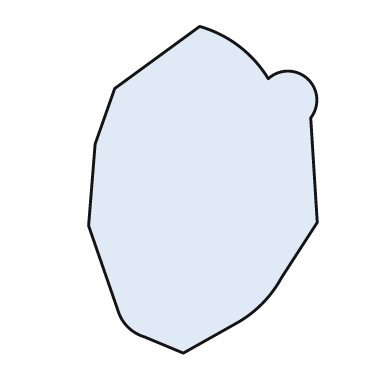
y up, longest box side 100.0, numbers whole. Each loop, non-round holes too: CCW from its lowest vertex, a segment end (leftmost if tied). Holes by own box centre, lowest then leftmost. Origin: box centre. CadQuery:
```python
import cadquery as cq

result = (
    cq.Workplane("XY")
    .moveTo(-6.0, -50.0)
    .lineTo(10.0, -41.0)
    .threePointArc((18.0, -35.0), (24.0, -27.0))
    .lineTo(35.0, -10.0)
    .lineTo(33.0, 22.0)
    .threePointArc((32.0, 34.0), (20.0, 34.0))
    .threePointArc((11.0, 44.0), (-1.0, 50.0))
    .lineTo(-27.0, 31.0)
    .lineTo(-33.0, 14.0)
    .lineTo(-35.0, -11.0)
    .lineTo(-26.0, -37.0)
    .threePointArc((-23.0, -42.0), (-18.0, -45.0))
    .close()
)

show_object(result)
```